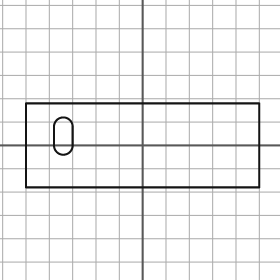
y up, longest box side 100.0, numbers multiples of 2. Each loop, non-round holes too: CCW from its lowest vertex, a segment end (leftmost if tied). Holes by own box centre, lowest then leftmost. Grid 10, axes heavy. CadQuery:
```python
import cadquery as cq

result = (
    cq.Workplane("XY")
    .moveTo(-50.0, -18.0)
    .lineTo(50.0, -18.0)
    .lineTo(50.0, 18.0)
    .lineTo(-50.0, 18.0)
    .close()
    .moveTo(-38.0, 0.0)
    .threePointArc((-34.0, -4.0), (-30.0, 0.0))
    .lineTo(-30.0, 8.0)
    .threePointArc((-34.0, 12.0), (-38.0, 8.0))
    .close()
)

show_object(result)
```